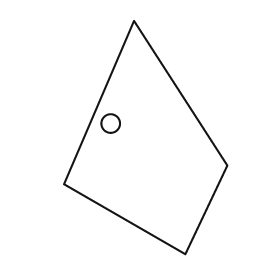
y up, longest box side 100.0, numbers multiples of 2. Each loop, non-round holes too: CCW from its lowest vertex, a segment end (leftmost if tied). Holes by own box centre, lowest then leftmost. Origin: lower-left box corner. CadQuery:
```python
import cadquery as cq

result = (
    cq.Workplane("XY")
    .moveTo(52.0, 0.0)
    .lineTo(70.0, 38.0)
    .lineTo(30.0, 100.0)
    .lineTo(0.0, 30.0)
    .close()
    .moveTo(20.0, 56.0)
    .circle(4.0)
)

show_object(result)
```